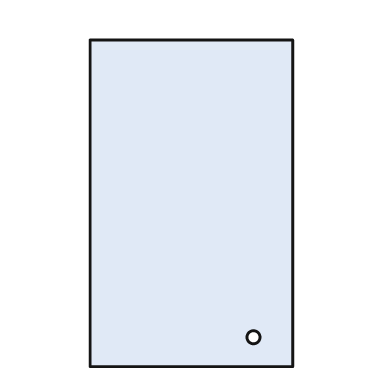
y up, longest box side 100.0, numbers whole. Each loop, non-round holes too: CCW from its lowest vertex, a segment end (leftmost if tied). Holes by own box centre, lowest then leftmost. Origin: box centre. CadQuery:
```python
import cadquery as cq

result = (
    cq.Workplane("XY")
    .moveTo(-31.0, -50.0)
    .lineTo(31.0, -50.0)
    .lineTo(31.0, 50.0)
    .lineTo(-31.0, 50.0)
    .close()
    .moveTo(19.0, -41.0)
    .circle(2.0)
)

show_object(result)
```